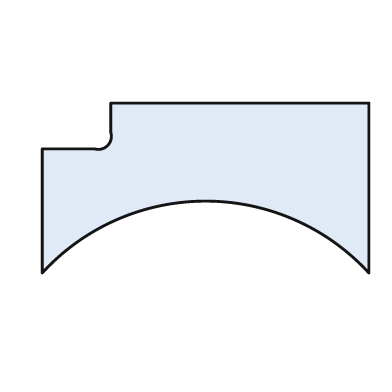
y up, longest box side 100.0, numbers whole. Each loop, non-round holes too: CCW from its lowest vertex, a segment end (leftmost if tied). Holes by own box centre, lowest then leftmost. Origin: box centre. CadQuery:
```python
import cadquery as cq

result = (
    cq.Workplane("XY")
    .moveTo(-50.0, -26.0)
    .threePointArc((0.0, -4.0), (50.0, -26.0))
    .lineTo(50.0, 26.0)
    .lineTo(-29.0, 26.0)
    .lineTo(-29.0, 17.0)
    .threePointArc((-30.0, 13.0), (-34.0, 12.0))
    .lineTo(-50.0, 12.0)
    .close()
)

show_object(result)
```